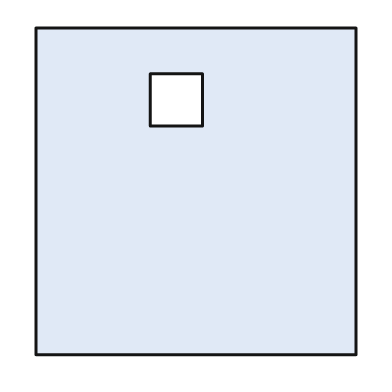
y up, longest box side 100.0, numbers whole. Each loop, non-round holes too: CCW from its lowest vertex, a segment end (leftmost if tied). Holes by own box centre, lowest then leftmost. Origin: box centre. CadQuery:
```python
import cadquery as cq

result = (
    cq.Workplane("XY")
    .moveTo(-49.0, -50.0)
    .lineTo(49.0, -50.0)
    .lineTo(49.0, 50.0)
    .lineTo(-49.0, 50.0)
    .close()
    .moveTo(-14.0, 20.0)
    .lineTo(2.0, 20.0)
    .lineTo(2.0, 36.0)
    .lineTo(-14.0, 36.0)
    .close()
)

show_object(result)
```